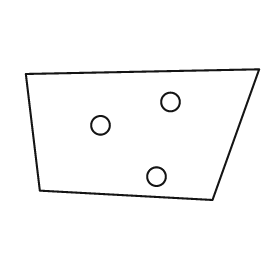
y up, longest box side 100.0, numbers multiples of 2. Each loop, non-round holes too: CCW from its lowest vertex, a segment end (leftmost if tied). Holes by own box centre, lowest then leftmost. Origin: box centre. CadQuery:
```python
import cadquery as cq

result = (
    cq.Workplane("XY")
    .moveTo(30.0, -28.0)
    .lineTo(50.0, 28.0)
    .lineTo(-50.0, 26.0)
    .lineTo(-44.0, -24.0)
    .close()
    .moveTo(6.0, -18.0)
    .circle(4.0)
    .moveTo(-18.0, 4.0)
    .circle(4.0)
    .moveTo(12.0, 14.0)
    .circle(4.0)
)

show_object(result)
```